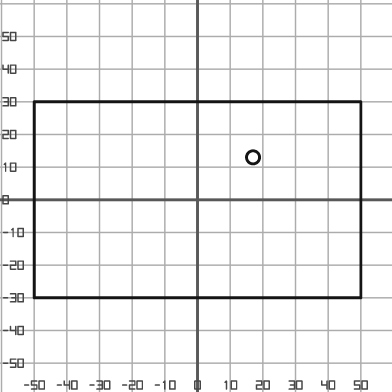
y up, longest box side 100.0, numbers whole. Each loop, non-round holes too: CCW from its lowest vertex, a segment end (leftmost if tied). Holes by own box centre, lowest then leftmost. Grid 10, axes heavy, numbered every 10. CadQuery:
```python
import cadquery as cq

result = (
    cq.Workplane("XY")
    .moveTo(-50.0, -30.0)
    .lineTo(50.0, -30.0)
    .lineTo(50.0, 30.0)
    .lineTo(-50.0, 30.0)
    .close()
    .moveTo(17.0, 13.0)
    .circle(2.0)
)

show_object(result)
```